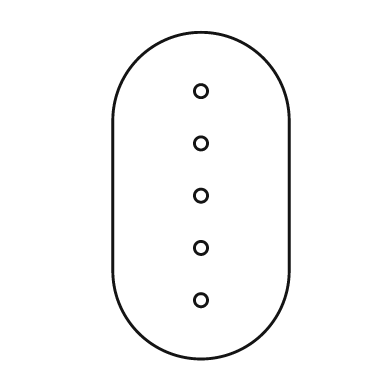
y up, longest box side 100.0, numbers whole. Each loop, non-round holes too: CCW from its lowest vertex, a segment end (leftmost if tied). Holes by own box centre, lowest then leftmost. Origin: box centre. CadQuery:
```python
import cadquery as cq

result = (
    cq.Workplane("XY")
    .moveTo(-27.0, -23.0)
    .threePointArc((0.0, -50.0), (27.0, -23.0))
    .lineTo(27.0, 23.0)
    .threePointArc((0.0, 50.0), (-27.0, 23.0))
    .close()
    .moveTo(0.0, -32.0)
    .circle(2.0)
    .moveTo(0.0, -16.0)
    .circle(2.0)
    .moveTo(0.0, 0.0)
    .circle(2.0)
    .moveTo(0.0, 16.0)
    .circle(2.0)
    .moveTo(0.0, 32.0)
    .circle(2.0)
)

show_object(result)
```